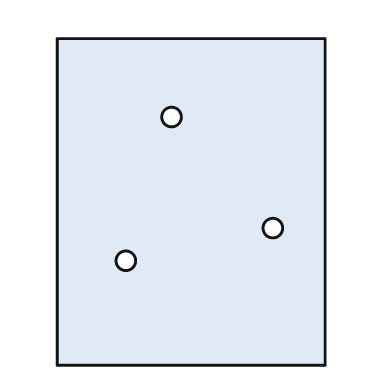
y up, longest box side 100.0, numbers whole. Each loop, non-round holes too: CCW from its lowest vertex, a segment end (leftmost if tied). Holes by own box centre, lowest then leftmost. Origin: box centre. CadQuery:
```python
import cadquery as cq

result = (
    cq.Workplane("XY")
    .moveTo(-41.0, -50.0)
    .lineTo(41.0, -50.0)
    .lineTo(41.0, 50.0)
    .lineTo(-41.0, 50.0)
    .close()
    .moveTo(-20.0, -18.0)
    .circle(3.0)
    .moveTo(25.0, -8.0)
    .circle(3.0)
    .moveTo(-6.0, 26.0)
    .circle(3.0)
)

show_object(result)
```